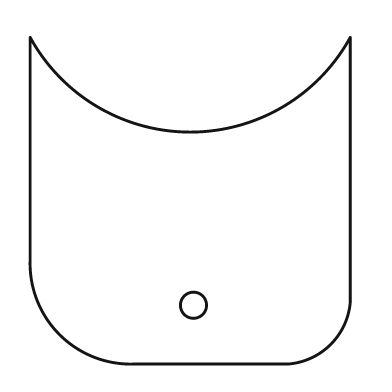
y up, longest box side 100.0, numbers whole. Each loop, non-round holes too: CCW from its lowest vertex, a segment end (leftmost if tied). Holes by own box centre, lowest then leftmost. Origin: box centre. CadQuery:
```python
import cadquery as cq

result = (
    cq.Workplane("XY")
    .moveTo(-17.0, -50.0)
    .lineTo(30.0, -50.0)
    .threePointArc((43.0, -44.0), (49.0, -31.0))
    .lineTo(49.0, 50.0)
    .threePointArc((0.0, 21.0), (-49.0, 50.0))
    .lineTo(-49.0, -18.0)
    .threePointArc((-40.0, -41.0), (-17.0, -50.0))
    .close()
    .moveTo(1.0, -32.0)
    .circle(4.0)
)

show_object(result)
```